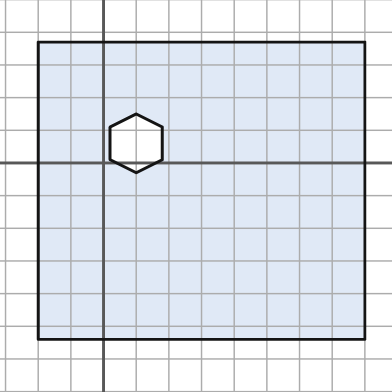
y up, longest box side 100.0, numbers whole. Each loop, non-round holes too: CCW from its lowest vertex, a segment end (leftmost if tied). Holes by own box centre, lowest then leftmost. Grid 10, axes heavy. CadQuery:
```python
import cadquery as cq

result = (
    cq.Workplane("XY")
    .moveTo(-20.0, -54.0)
    .lineTo(80.0, -54.0)
    .lineTo(80.0, 37.0)
    .lineTo(-20.0, 37.0)
    .close()
    .moveTo(10.0, -3.0)
    .lineTo(18.0, 1.0)
    .lineTo(18.0, 11.0)
    .lineTo(10.0, 15.0)
    .lineTo(2.0, 11.0)
    .lineTo(2.0, 1.0)
    .close()
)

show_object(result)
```